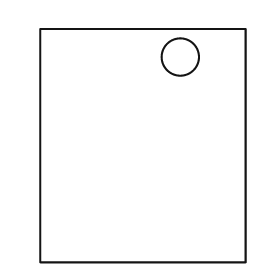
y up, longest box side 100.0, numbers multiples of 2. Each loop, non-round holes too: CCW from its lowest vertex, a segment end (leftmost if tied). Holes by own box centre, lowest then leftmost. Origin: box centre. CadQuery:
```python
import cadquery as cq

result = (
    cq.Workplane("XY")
    .moveTo(-44.0, -50.0)
    .lineTo(44.0, -50.0)
    .lineTo(44.0, 50.0)
    .lineTo(-44.0, 50.0)
    .close()
    .moveTo(16.0, 38.0)
    .circle(8.0)
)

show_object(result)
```